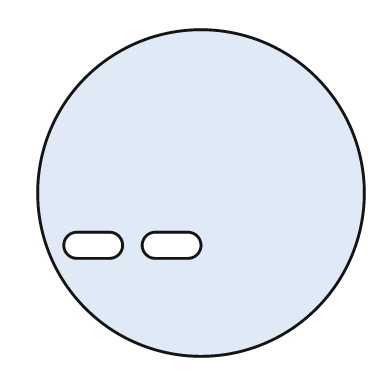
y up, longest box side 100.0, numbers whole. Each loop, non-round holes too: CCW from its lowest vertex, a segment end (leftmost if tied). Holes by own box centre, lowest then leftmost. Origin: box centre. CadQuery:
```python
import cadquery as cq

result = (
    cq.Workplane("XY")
    .moveTo(0.0, 0.0)
    .circle(50.0)
    .moveTo(-38.0, -20.0)
    .lineTo(-28.0, -20.0)
    .threePointArc((-24.0, -16.0), (-28.0, -12.0))
    .lineTo(-38.0, -12.0)
    .threePointArc((-42.0, -16.0), (-38.0, -20.0))
    .close()
    .moveTo(-14.0, -20.0)
    .lineTo(-4.0, -20.0)
    .threePointArc((0.0, -16.0), (-4.0, -12.0))
    .lineTo(-14.0, -12.0)
    .threePointArc((-18.0, -16.0), (-14.0, -20.0))
    .close()
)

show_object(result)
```